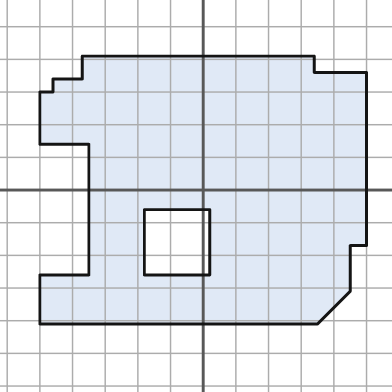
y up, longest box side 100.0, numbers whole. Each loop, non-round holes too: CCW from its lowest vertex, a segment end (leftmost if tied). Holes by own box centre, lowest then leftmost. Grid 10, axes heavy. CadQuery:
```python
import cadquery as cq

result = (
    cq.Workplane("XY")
    .moveTo(-50.0, -41.0)
    .lineTo(35.0, -41.0)
    .lineTo(45.0, -31.0)
    .lineTo(45.0, -17.0)
    .lineTo(50.0, -17.0)
    .lineTo(50.0, 36.0)
    .lineTo(34.0, 36.0)
    .lineTo(34.0, 41.0)
    .lineTo(-37.0, 41.0)
    .lineTo(-37.0, 34.0)
    .lineTo(-46.0, 34.0)
    .lineTo(-46.0, 30.0)
    .lineTo(-50.0, 30.0)
    .lineTo(-50.0, 14.0)
    .lineTo(-35.0, 14.0)
    .lineTo(-35.0, -26.0)
    .lineTo(-50.0, -26.0)
    .close()
    .moveTo(-18.0, -26.0)
    .lineTo(2.0, -26.0)
    .lineTo(2.0, -6.0)
    .lineTo(-18.0, -6.0)
    .close()
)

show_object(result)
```